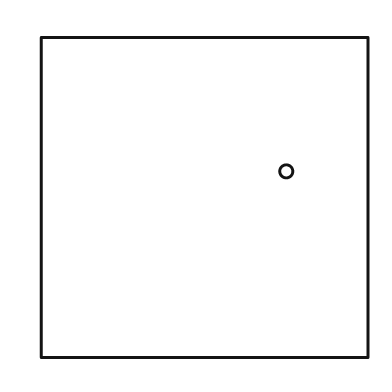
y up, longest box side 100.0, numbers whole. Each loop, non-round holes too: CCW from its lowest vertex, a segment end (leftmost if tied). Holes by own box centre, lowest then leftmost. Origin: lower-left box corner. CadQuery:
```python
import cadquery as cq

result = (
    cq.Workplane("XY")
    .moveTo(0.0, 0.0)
    .lineTo(100.0, 0.0)
    .lineTo(100.0, 98.0)
    .lineTo(0.0, 98.0)
    .close()
    .moveTo(75.0, 57.0)
    .circle(2.0)
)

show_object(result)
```